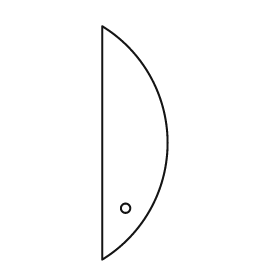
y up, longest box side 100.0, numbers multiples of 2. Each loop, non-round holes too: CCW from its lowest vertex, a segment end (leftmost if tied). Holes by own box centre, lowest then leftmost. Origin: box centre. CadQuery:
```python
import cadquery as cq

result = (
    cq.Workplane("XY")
    .moveTo(-14.0, -50.0)
    .threePointArc((14.0, 0.0), (-14.0, 50.0))
    .close()
    .moveTo(-4.0, -28.0)
    .circle(2.0)
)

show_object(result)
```